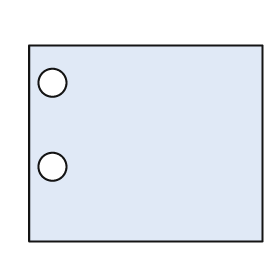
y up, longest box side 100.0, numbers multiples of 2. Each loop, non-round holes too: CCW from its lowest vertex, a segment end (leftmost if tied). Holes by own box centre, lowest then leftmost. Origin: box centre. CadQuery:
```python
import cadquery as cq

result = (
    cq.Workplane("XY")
    .moveTo(-50.0, -42.0)
    .lineTo(50.0, -42.0)
    .lineTo(50.0, 42.0)
    .lineTo(-50.0, 42.0)
    .close()
    .moveTo(-40.0, -10.0)
    .circle(6.0)
    .moveTo(-40.0, 26.0)
    .circle(6.0)
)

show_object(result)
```